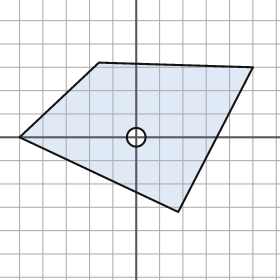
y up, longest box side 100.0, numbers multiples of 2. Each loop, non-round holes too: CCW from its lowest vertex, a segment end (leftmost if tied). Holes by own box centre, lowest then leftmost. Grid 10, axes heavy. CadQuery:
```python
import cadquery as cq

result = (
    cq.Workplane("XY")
    .moveTo(18.0, -32.0)
    .lineTo(50.0, 30.0)
    .lineTo(-16.0, 32.0)
    .lineTo(-50.0, 0.0)
    .close()
    .moveTo(0.0, 0.0)
    .circle(4.0)
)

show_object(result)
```